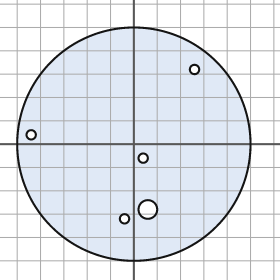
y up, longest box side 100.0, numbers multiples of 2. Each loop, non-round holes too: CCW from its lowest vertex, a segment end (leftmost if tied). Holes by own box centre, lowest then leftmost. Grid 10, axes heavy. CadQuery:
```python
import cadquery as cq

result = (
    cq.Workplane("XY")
    .moveTo(0.0, 0.0)
    .circle(50.0)
    .moveTo(-4.0, -32.0)
    .circle(2.0)
    .moveTo(6.0, -28.0)
    .circle(4.0)
    .moveTo(4.0, -6.0)
    .circle(2.0)
    .moveTo(-44.0, 4.0)
    .circle(2.0)
    .moveTo(26.0, 32.0)
    .circle(2.0)
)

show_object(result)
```